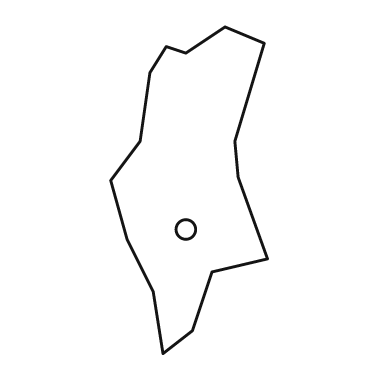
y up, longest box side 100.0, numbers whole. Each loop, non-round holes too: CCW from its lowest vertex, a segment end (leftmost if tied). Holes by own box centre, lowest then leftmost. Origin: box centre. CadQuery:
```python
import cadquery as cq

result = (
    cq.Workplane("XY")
    .moveTo(-8.0, -50.0)
    .lineTo(1.0, -43.0)
    .lineTo(7.0, -25.0)
    .lineTo(24.0, -21.0)
    .lineTo(15.0, 4.0)
    .lineTo(14.0, 15.0)
    .lineTo(23.0, 45.0)
    .lineTo(11.0, 50.0)
    .lineTo(-1.0, 42.0)
    .lineTo(-7.0, 44.0)
    .lineTo(-12.0, 36.0)
    .lineTo(-15.0, 15.0)
    .lineTo(-24.0, 3.0)
    .lineTo(-19.0, -15.0)
    .lineTo(-11.0, -31.0)
    .close()
    .moveTo(-1.0, -12.0)
    .circle(3.0)
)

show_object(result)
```